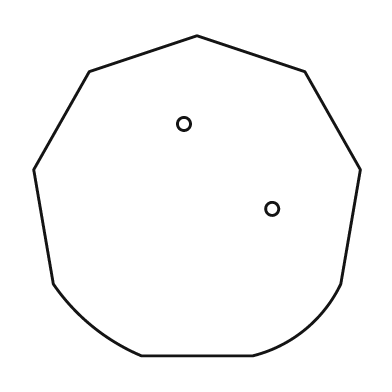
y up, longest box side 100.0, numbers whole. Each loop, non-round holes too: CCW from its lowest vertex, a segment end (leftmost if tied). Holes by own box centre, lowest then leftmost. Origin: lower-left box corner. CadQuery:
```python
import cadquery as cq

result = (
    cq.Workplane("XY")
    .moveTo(33.0, 0.0)
    .lineTo(67.0, 0.0)
    .threePointArc((83.0, 8.0), (94.0, 22.0))
    .lineTo(100.0, 57.0)
    .lineTo(83.0, 87.0)
    .lineTo(50.0, 98.0)
    .lineTo(17.0, 87.0)
    .lineTo(0.0, 57.0)
    .lineTo(6.0, 22.0)
    .threePointArc((18.0, 9.0), (33.0, 0.0))
    .close()
    .moveTo(73.0, 45.0)
    .circle(2.0)
    .moveTo(46.0, 71.0)
    .circle(2.0)
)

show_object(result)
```